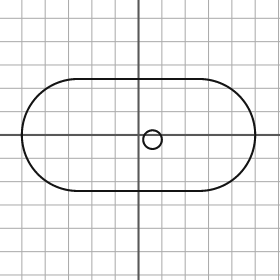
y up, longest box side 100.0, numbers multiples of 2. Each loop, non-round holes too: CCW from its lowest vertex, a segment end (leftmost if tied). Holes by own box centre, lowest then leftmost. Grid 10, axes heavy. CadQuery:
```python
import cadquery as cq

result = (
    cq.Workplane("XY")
    .moveTo(-26.0, -24.0)
    .lineTo(26.0, -24.0)
    .threePointArc((50.0, 0.0), (26.0, 24.0))
    .lineTo(-26.0, 24.0)
    .threePointArc((-50.0, 0.0), (-26.0, -24.0))
    .close()
    .moveTo(6.0, -2.0)
    .circle(4.0)
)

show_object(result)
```